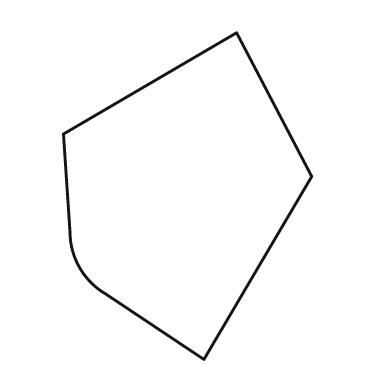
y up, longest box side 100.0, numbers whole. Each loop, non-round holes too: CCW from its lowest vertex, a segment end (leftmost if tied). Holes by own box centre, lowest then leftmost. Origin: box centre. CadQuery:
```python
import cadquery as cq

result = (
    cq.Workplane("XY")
    .moveTo(5.0, -50.0)
    .lineTo(38.0, 6.0)
    .lineTo(15.0, 50.0)
    .lineTo(-38.0, 19.0)
    .lineTo(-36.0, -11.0)
    .threePointArc((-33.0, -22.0), (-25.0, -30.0))
    .close()
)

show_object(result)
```